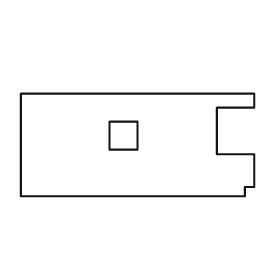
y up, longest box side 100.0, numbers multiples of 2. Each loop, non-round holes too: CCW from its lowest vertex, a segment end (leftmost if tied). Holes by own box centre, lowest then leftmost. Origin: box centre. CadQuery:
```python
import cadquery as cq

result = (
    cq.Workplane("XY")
    .moveTo(-50.0, -22.0)
    .lineTo(46.0, -22.0)
    .lineTo(46.0, -18.0)
    .lineTo(50.0, -18.0)
    .lineTo(50.0, -4.0)
    .lineTo(34.0, -4.0)
    .lineTo(34.0, 16.0)
    .lineTo(50.0, 16.0)
    .lineTo(50.0, 22.0)
    .lineTo(-50.0, 22.0)
    .close()
    .moveTo(-12.0, -2.0)
    .lineTo(0.0, -2.0)
    .lineTo(0.0, 10.0)
    .lineTo(-12.0, 10.0)
    .close()
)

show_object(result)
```